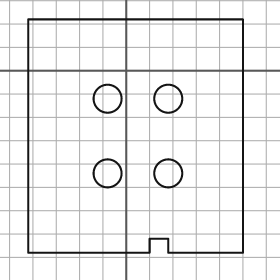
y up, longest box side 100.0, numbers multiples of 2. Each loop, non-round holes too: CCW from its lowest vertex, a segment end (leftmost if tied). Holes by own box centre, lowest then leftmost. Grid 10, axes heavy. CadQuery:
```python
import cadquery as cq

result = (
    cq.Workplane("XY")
    .moveTo(-42.0, -78.0)
    .lineTo(10.0, -78.0)
    .lineTo(10.0, -72.0)
    .lineTo(18.0, -72.0)
    .lineTo(18.0, -78.0)
    .lineTo(50.0, -78.0)
    .lineTo(50.0, 22.0)
    .lineTo(-42.0, 22.0)
    .close()
    .moveTo(-8.0, -44.0)
    .circle(6.0)
    .moveTo(18.0, -44.0)
    .circle(6.0)
    .moveTo(-8.0, -12.0)
    .circle(6.0)
    .moveTo(18.0, -12.0)
    .circle(6.0)
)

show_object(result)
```